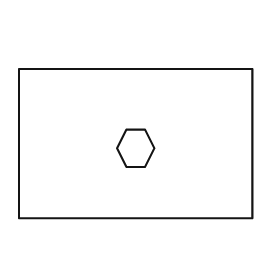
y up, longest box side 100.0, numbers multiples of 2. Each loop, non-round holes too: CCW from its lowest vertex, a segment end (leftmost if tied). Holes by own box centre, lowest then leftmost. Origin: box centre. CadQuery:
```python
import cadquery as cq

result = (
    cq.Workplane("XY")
    .moveTo(-50.0, -32.0)
    .lineTo(50.0, -32.0)
    .lineTo(50.0, 32.0)
    .lineTo(-50.0, 32.0)
    .close()
    .moveTo(-4.0, -10.0)
    .lineTo(4.0, -10.0)
    .lineTo(8.0, -2.0)
    .lineTo(4.0, 6.0)
    .lineTo(-4.0, 6.0)
    .lineTo(-8.0, -2.0)
    .close()
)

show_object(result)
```